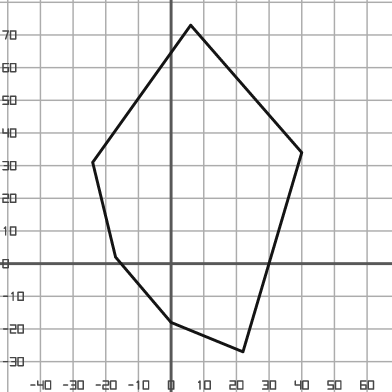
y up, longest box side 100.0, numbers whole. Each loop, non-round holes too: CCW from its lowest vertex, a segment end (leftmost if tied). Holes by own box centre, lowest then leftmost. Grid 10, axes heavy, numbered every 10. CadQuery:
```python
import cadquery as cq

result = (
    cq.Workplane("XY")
    .moveTo(22.0, -27.0)
    .lineTo(40.0, 34.0)
    .lineTo(6.0, 73.0)
    .lineTo(-24.0, 31.0)
    .lineTo(-17.0, 2.0)
    .lineTo(0.0, -18.0)
    .close()
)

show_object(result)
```